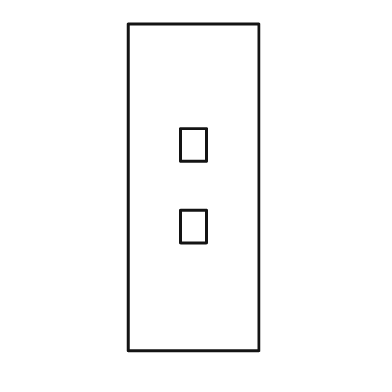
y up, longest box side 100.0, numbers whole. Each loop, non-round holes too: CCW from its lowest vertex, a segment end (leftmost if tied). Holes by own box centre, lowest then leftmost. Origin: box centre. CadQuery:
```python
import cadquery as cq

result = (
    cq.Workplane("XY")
    .moveTo(-20.0, -50.0)
    .lineTo(20.0, -50.0)
    .lineTo(20.0, 50.0)
    .lineTo(-20.0, 50.0)
    .close()
    .moveTo(-4.0, -17.0)
    .lineTo(4.0, -17.0)
    .lineTo(4.0, -7.0)
    .lineTo(-4.0, -7.0)
    .close()
    .moveTo(-4.0, 8.0)
    .lineTo(4.0, 8.0)
    .lineTo(4.0, 18.0)
    .lineTo(-4.0, 18.0)
    .close()
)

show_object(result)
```